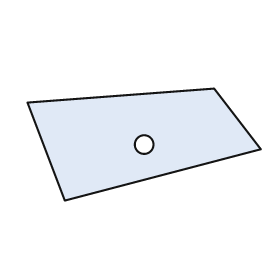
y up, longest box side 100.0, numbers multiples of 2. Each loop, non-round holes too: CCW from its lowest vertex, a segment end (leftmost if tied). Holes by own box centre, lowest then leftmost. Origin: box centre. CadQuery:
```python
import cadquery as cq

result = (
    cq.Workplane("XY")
    .moveTo(-34.0, -24.0)
    .lineTo(50.0, -2.0)
    .lineTo(30.0, 24.0)
    .lineTo(-50.0, 18.0)
    .close()
    .moveTo(0.0, 0.0)
    .circle(4.0)
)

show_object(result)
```